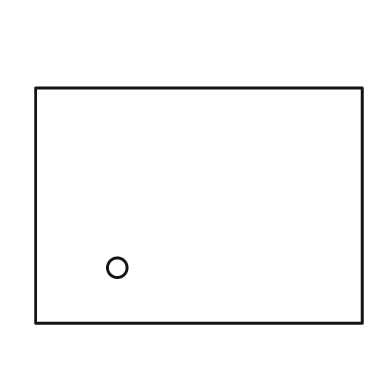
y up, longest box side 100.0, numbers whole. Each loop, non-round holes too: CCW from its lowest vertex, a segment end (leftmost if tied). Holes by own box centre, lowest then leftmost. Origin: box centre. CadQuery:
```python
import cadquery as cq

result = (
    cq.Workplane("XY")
    .moveTo(-50.0, -36.0)
    .lineTo(50.0, -36.0)
    .lineTo(50.0, 36.0)
    .lineTo(-50.0, 36.0)
    .close()
    .moveTo(-25.0, -19.0)
    .circle(3.0)
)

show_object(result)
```